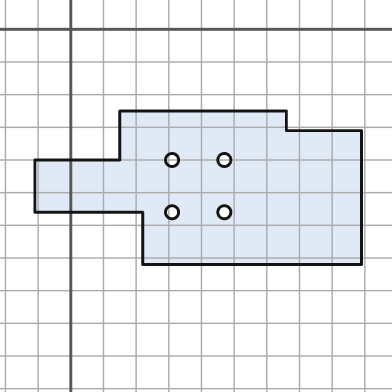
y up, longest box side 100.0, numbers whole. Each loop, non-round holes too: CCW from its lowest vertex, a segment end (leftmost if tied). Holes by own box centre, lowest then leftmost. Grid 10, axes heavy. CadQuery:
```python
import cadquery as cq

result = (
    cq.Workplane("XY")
    .moveTo(22.0, -72.0)
    .lineTo(89.0, -72.0)
    .lineTo(89.0, -31.0)
    .lineTo(66.0, -31.0)
    .lineTo(66.0, -25.0)
    .lineTo(15.0, -25.0)
    .lineTo(15.0, -40.0)
    .lineTo(-11.0, -40.0)
    .lineTo(-11.0, -56.0)
    .lineTo(22.0, -56.0)
    .close()
    .moveTo(31.0, -56.0)
    .circle(2.0)
    .moveTo(47.0, -56.0)
    .circle(2.0)
    .moveTo(31.0, -40.0)
    .circle(2.0)
    .moveTo(47.0, -40.0)
    .circle(2.0)
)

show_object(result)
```